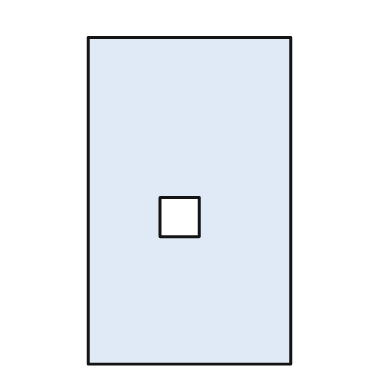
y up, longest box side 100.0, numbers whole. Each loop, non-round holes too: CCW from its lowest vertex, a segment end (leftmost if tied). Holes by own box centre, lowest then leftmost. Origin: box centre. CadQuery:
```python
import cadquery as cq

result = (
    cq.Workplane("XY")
    .moveTo(-31.0, -50.0)
    .lineTo(31.0, -50.0)
    .lineTo(31.0, 50.0)
    .lineTo(-31.0, 50.0)
    .close()
    .moveTo(-9.0, -11.0)
    .lineTo(3.0, -11.0)
    .lineTo(3.0, 1.0)
    .lineTo(-9.0, 1.0)
    .close()
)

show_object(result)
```